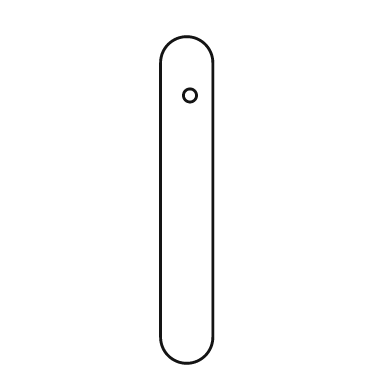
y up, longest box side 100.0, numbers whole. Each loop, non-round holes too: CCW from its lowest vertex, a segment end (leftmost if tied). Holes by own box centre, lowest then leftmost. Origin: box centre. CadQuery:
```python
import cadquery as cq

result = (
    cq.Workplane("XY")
    .moveTo(-8.0, -42.0)
    .threePointArc((0.0, -50.0), (8.0, -42.0))
    .lineTo(8.0, 42.0)
    .threePointArc((0.0, 50.0), (-8.0, 42.0))
    .close()
    .moveTo(1.0, 32.0)
    .circle(2.0)
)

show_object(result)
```